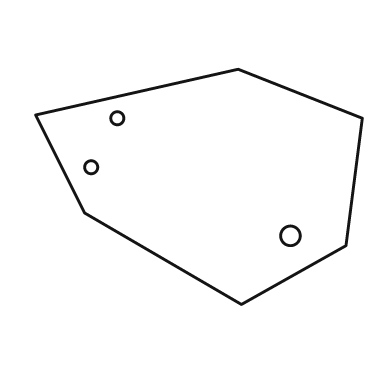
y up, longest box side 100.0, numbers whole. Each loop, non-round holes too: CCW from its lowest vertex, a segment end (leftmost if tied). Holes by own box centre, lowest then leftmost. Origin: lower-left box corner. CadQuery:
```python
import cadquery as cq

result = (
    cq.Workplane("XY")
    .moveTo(63.0, 0.0)
    .lineTo(95.0, 18.0)
    .lineTo(100.0, 57.0)
    .lineTo(62.0, 72.0)
    .lineTo(0.0, 58.0)
    .lineTo(15.0, 28.0)
    .close()
    .moveTo(78.0, 21.0)
    .circle(3.0)
    .moveTo(17.0, 42.0)
    .circle(2.0)
    .moveTo(25.0, 57.0)
    .circle(2.0)
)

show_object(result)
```